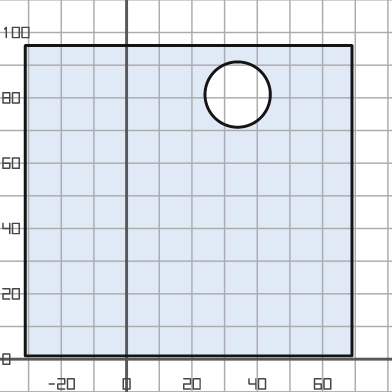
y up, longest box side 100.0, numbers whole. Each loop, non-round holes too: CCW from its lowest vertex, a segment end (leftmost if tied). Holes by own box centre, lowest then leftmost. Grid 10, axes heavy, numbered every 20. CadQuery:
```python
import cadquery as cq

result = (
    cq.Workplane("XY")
    .moveTo(-31.0, 1.0)
    .lineTo(69.0, 1.0)
    .lineTo(69.0, 96.0)
    .lineTo(-31.0, 96.0)
    .close()
    .moveTo(34.0, 81.0)
    .circle(10.0)
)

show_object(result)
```